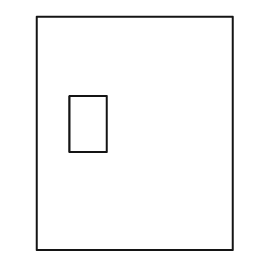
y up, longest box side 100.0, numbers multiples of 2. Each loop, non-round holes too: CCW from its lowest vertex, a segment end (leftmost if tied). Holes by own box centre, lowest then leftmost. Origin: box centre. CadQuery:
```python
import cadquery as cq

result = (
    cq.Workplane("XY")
    .moveTo(-42.0, -50.0)
    .lineTo(42.0, -50.0)
    .lineTo(42.0, 50.0)
    .lineTo(-42.0, 50.0)
    .close()
    .moveTo(-28.0, -8.0)
    .lineTo(-12.0, -8.0)
    .lineTo(-12.0, 16.0)
    .lineTo(-28.0, 16.0)
    .close()
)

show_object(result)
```